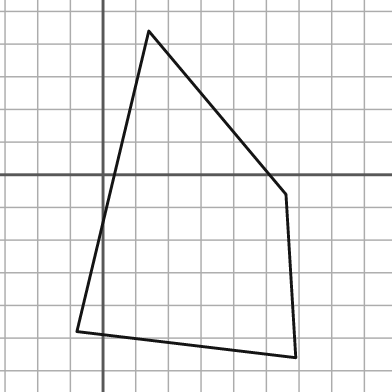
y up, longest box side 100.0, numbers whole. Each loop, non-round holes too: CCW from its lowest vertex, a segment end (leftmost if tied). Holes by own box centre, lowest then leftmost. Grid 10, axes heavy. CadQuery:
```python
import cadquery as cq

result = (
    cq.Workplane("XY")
    .moveTo(59.0, -56.0)
    .lineTo(56.0, -6.0)
    .lineTo(14.0, 44.0)
    .lineTo(-8.0, -48.0)
    .close()
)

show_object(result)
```